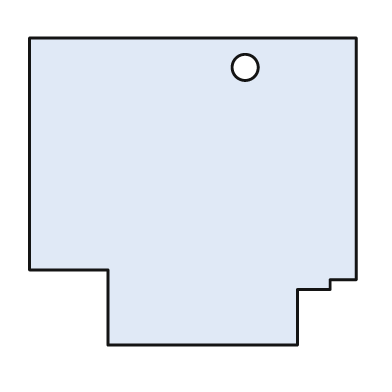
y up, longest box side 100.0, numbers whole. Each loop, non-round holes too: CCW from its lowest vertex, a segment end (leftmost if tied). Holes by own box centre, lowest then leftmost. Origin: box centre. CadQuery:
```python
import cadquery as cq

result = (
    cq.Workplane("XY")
    .moveTo(-26.0, -47.0)
    .lineTo(32.0, -47.0)
    .lineTo(32.0, -30.0)
    .lineTo(42.0, -30.0)
    .lineTo(42.0, -27.0)
    .lineTo(50.0, -27.0)
    .lineTo(50.0, 47.0)
    .lineTo(-50.0, 47.0)
    .lineTo(-50.0, -24.0)
    .lineTo(-26.0, -24.0)
    .close()
    .moveTo(16.0, 38.0)
    .circle(4.0)
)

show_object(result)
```